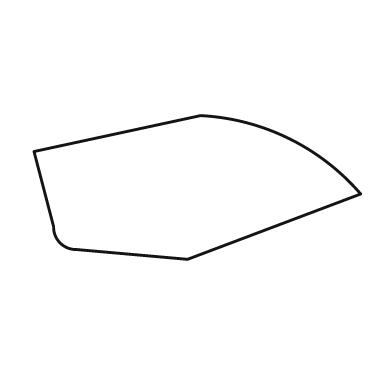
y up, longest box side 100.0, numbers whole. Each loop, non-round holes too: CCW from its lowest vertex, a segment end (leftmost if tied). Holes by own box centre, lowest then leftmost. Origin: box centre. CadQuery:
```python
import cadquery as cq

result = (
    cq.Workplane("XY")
    .moveTo(-3.0, -22.0)
    .lineTo(50.0, -2.0)
    .threePointArc((28.0, 15.0), (1.0, 22.0))
    .lineTo(-50.0, 11.0)
    .lineTo(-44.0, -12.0)
    .threePointArc((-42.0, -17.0), (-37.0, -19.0))
    .close()
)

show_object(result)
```